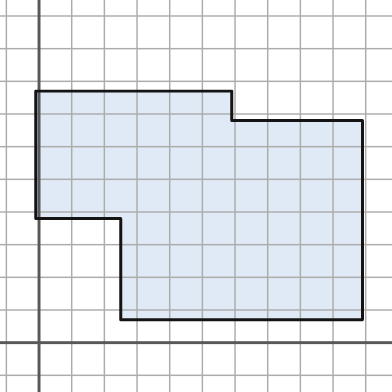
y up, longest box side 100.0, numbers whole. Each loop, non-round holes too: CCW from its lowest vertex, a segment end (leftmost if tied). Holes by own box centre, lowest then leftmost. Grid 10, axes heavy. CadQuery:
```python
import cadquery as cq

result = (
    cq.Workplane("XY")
    .moveTo(25.0, 7.0)
    .lineTo(99.0, 7.0)
    .lineTo(99.0, 68.0)
    .lineTo(59.0, 68.0)
    .lineTo(59.0, 77.0)
    .lineTo(-1.0, 77.0)
    .lineTo(-1.0, 38.0)
    .lineTo(25.0, 38.0)
    .close()
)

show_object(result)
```